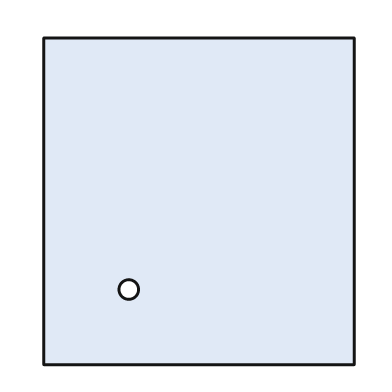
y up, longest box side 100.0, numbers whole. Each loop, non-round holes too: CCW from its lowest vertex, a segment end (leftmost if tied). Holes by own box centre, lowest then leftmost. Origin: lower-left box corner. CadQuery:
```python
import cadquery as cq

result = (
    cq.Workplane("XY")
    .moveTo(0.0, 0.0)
    .lineTo(95.0, 0.0)
    .lineTo(95.0, 100.0)
    .lineTo(0.0, 100.0)
    .close()
    .moveTo(26.0, 23.0)
    .circle(3.0)
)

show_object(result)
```